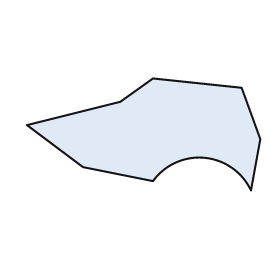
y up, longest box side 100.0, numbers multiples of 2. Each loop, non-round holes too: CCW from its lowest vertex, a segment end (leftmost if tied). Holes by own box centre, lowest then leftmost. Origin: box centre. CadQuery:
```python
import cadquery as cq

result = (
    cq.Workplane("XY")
    .moveTo(46.0, -24.0)
    .lineTo(50.0, -2.0)
    .lineTo(42.0, 20.0)
    .lineTo(4.0, 24.0)
    .lineTo(-10.0, 14.0)
    .lineTo(-50.0, 4.0)
    .lineTo(-26.0, -14.0)
    .lineTo(4.0, -20.0)
    .threePointArc((26.0, -10.0), (46.0, -24.0))
    .close()
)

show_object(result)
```